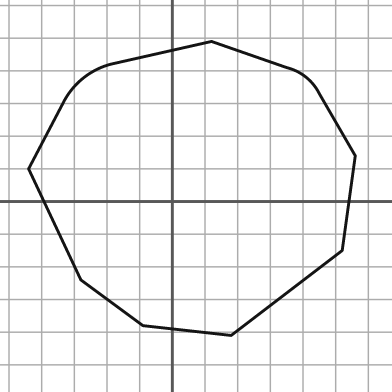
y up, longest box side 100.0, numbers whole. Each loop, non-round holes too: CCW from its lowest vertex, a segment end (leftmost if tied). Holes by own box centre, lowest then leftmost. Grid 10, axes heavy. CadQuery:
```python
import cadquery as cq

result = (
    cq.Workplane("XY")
    .moveTo(18.0, -41.0)
    .lineTo(52.0, -15.0)
    .lineTo(56.0, 14.0)
    .lineTo(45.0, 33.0)
    .threePointArc((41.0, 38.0), (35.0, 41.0))
    .lineTo(12.0, 49.0)
    .lineTo(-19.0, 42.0)
    .threePointArc((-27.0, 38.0), (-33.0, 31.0))
    .lineTo(-44.0, 10.0)
    .lineTo(-28.0, -24.0)
    .lineTo(-9.0, -38.0)
    .close()
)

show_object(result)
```